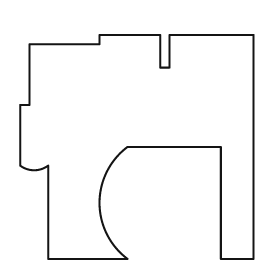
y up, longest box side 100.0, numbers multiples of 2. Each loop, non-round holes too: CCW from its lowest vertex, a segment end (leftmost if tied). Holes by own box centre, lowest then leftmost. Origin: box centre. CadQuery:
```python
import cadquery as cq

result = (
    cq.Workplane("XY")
    .moveTo(-38.0, -48.0)
    .lineTo(-4.0, -48.0)
    .threePointArc((-16.0, -24.0), (-4.0, 0.0))
    .lineTo(36.0, 0.0)
    .lineTo(36.0, -48.0)
    .lineTo(50.0, -48.0)
    .lineTo(50.0, 48.0)
    .lineTo(14.0, 48.0)
    .lineTo(14.0, 34.0)
    .lineTo(10.0, 34.0)
    .lineTo(10.0, 48.0)
    .lineTo(-16.0, 48.0)
    .lineTo(-16.0, 44.0)
    .lineTo(-46.0, 44.0)
    .lineTo(-46.0, 18.0)
    .lineTo(-50.0, 18.0)
    .lineTo(-50.0, -8.0)
    .threePointArc((-44.0, -10.0), (-38.0, -8.0))
    .close()
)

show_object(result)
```